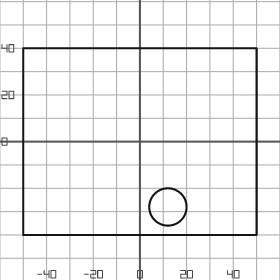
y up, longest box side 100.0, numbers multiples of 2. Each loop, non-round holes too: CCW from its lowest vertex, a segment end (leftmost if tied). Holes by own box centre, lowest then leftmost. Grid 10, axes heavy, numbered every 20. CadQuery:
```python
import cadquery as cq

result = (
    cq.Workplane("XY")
    .moveTo(-50.0, -40.0)
    .lineTo(50.0, -40.0)
    .lineTo(50.0, 40.0)
    .lineTo(-50.0, 40.0)
    .close()
    .moveTo(12.0, -28.0)
    .circle(8.0)
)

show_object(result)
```